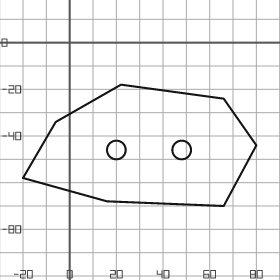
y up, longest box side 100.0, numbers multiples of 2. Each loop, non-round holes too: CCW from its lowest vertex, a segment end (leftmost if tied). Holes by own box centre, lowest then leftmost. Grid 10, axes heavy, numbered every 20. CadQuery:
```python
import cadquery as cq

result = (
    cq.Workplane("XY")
    .moveTo(66.0, -70.0)
    .lineTo(80.0, -44.0)
    .lineTo(66.0, -24.0)
    .lineTo(22.0, -18.0)
    .lineTo(-6.0, -34.0)
    .lineTo(-20.0, -58.0)
    .lineTo(16.0, -68.0)
    .close()
    .moveTo(20.0, -46.0)
    .circle(4.0)
    .moveTo(48.0, -46.0)
    .circle(4.0)
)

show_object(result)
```